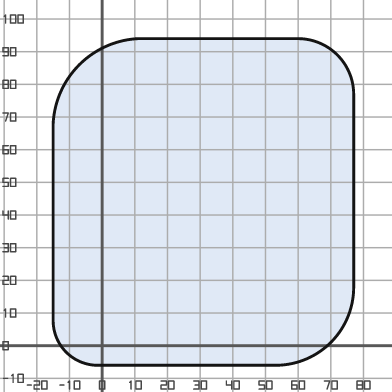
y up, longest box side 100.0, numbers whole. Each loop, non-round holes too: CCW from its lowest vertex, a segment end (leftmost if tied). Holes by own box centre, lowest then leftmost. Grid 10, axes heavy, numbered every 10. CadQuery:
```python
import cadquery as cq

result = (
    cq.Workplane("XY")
    .moveTo(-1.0, -6.0)
    .lineTo(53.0, -6.0)
    .threePointArc((70.0, 1.0), (77.0, 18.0))
    .lineTo(77.0, 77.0)
    .threePointArc((72.0, 89.0), (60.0, 94.0))
    .lineTo(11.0, 94.0)
    .threePointArc((-7.0, 86.0), (-15.0, 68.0))
    .lineTo(-15.0, 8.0)
    .threePointArc((-11.0, -2.0), (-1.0, -6.0))
    .close()
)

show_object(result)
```